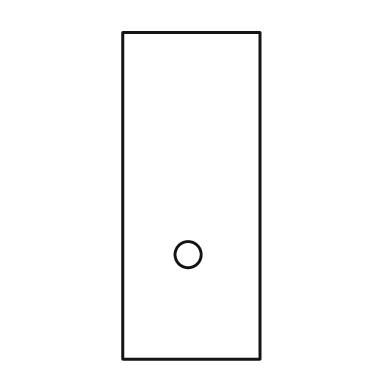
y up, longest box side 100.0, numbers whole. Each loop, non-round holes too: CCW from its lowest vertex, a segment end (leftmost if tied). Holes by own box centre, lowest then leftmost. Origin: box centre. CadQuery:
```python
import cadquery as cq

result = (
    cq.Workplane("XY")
    .moveTo(-21.0, -50.0)
    .lineTo(21.0, -50.0)
    .lineTo(21.0, 50.0)
    .lineTo(-21.0, 50.0)
    .close()
    .moveTo(-1.0, -18.0)
    .circle(4.0)
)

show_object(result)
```